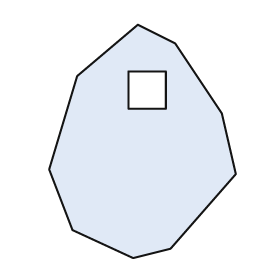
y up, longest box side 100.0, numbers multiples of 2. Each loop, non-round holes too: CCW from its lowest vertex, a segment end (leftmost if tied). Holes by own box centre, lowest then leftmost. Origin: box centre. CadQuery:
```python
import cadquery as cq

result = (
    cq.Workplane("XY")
    .moveTo(-4.0, -50.0)
    .lineTo(12.0, -46.0)
    .lineTo(40.0, -14.0)
    .lineTo(34.0, 12.0)
    .lineTo(14.0, 42.0)
    .lineTo(-2.0, 50.0)
    .lineTo(-28.0, 28.0)
    .lineTo(-40.0, -12.0)
    .lineTo(-30.0, -38.0)
    .close()
    .moveTo(-6.0, 14.0)
    .lineTo(10.0, 14.0)
    .lineTo(10.0, 30.0)
    .lineTo(-6.0, 30.0)
    .close()
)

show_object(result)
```